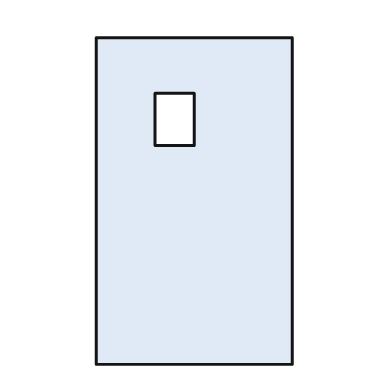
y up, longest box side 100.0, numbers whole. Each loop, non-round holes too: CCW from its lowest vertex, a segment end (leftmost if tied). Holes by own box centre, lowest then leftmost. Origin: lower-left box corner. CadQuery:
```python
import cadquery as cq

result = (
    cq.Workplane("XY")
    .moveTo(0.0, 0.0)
    .lineTo(60.0, 0.0)
    .lineTo(60.0, 100.0)
    .lineTo(0.0, 100.0)
    .close()
    .moveTo(18.0, 67.0)
    .lineTo(30.0, 67.0)
    .lineTo(30.0, 83.0)
    .lineTo(18.0, 83.0)
    .close()
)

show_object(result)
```